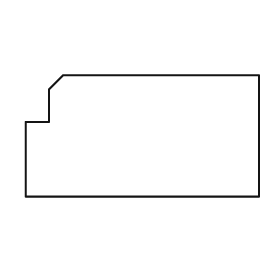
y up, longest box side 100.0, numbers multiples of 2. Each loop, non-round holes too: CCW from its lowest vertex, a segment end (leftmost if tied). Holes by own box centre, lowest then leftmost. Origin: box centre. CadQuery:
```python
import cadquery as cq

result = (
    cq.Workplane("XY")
    .moveTo(-50.0, -26.0)
    .lineTo(50.0, -26.0)
    .lineTo(50.0, 26.0)
    .lineTo(-34.0, 26.0)
    .lineTo(-40.0, 20.0)
    .lineTo(-40.0, 6.0)
    .lineTo(-50.0, 6.0)
    .close()
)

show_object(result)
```